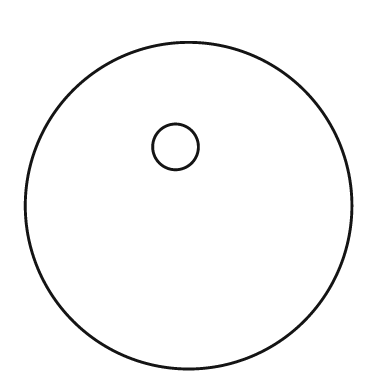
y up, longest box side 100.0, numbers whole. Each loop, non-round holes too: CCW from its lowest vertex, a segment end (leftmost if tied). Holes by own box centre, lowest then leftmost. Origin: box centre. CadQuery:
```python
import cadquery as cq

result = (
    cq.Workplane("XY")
    .moveTo(0.0, 0.0)
    .circle(50.0)
    .moveTo(-4.0, 18.0)
    .circle(7.0)
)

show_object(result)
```